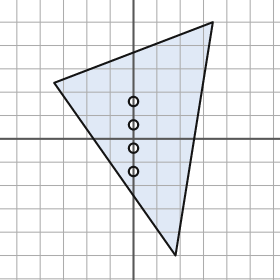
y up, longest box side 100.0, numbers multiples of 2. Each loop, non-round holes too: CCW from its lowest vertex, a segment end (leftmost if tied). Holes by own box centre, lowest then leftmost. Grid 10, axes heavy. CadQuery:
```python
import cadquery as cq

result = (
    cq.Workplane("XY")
    .moveTo(18.0, -50.0)
    .lineTo(34.0, 50.0)
    .lineTo(-34.0, 24.0)
    .close()
    .moveTo(0.0, -14.0)
    .circle(2.0)
    .moveTo(0.0, -4.0)
    .circle(2.0)
    .moveTo(0.0, 6.0)
    .circle(2.0)
    .moveTo(0.0, 16.0)
    .circle(2.0)
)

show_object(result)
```